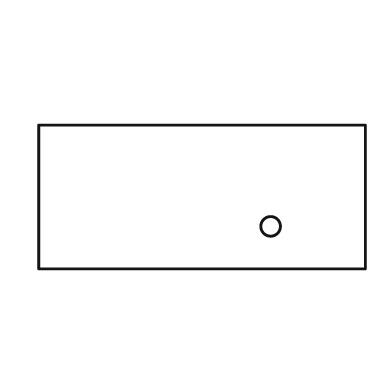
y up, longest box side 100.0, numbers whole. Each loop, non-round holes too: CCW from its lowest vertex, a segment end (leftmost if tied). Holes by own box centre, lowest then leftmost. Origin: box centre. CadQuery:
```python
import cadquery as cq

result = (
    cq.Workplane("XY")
    .moveTo(-50.0, -22.0)
    .lineTo(50.0, -22.0)
    .lineTo(50.0, 22.0)
    .lineTo(-50.0, 22.0)
    .close()
    .moveTo(21.0, -9.0)
    .circle(3.0)
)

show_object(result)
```